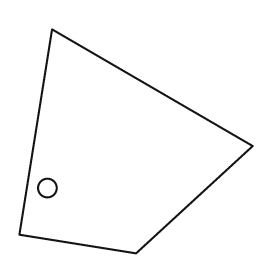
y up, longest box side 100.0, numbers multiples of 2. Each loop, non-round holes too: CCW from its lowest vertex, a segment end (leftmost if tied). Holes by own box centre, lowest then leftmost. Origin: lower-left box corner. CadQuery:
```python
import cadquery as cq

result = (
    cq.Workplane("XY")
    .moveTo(50.0, 0.0)
    .lineTo(100.0, 46.0)
    .lineTo(14.0, 96.0)
    .lineTo(0.0, 8.0)
    .close()
    .moveTo(12.0, 28.0)
    .circle(4.0)
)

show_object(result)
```